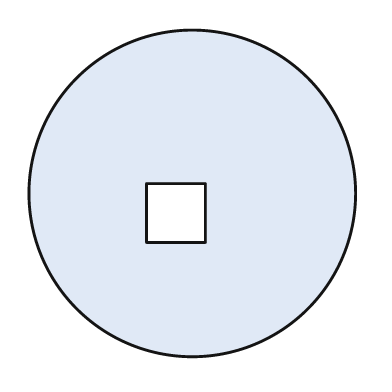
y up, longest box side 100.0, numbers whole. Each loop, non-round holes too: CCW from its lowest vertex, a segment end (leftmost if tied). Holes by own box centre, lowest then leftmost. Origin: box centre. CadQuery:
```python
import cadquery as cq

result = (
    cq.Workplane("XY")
    .moveTo(0.0, 0.0)
    .circle(50.0)
    .moveTo(-14.0, -15.0)
    .lineTo(4.0, -15.0)
    .lineTo(4.0, 3.0)
    .lineTo(-14.0, 3.0)
    .close()
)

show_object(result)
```